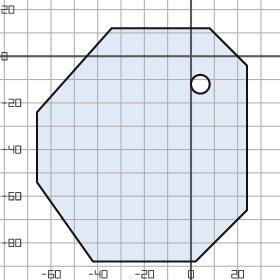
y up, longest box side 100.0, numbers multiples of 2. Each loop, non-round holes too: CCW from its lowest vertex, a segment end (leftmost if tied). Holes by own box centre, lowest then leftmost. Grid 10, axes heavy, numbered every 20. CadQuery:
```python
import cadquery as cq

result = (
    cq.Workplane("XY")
    .moveTo(-42.0, -88.0)
    .lineTo(2.0, -88.0)
    .lineTo(24.0, -66.0)
    .lineTo(24.0, -4.0)
    .lineTo(8.0, 12.0)
    .lineTo(-34.0, 12.0)
    .lineTo(-66.0, -24.0)
    .lineTo(-66.0, -54.0)
    .close()
    .moveTo(4.0, -12.0)
    .circle(4.0)
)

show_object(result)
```